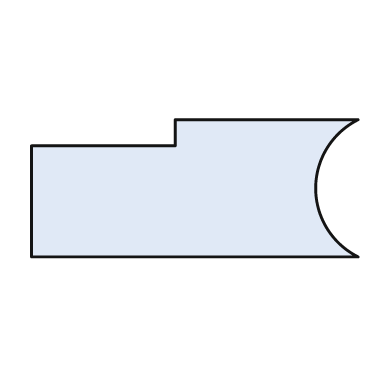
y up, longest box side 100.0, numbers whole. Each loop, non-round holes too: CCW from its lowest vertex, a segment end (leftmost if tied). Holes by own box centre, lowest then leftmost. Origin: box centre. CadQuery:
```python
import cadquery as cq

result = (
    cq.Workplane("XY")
    .moveTo(-50.0, -21.0)
    .lineTo(50.0, -21.0)
    .threePointArc((37.0, 0.0), (50.0, 21.0))
    .lineTo(-6.0, 21.0)
    .lineTo(-6.0, 13.0)
    .lineTo(-50.0, 13.0)
    .close()
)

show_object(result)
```